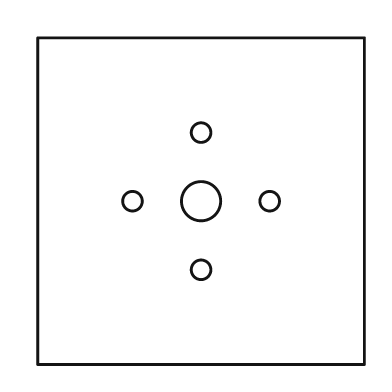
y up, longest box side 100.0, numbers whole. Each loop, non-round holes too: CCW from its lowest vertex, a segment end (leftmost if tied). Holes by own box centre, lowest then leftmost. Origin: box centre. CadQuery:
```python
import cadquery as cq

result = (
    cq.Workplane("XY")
    .moveTo(-50.0, -50.0)
    .lineTo(50.0, -50.0)
    .lineTo(50.0, 50.0)
    .lineTo(-50.0, 50.0)
    .close()
    .moveTo(0.0, -21.0)
    .circle(3.0)
    .moveTo(-21.0, 0.0)
    .circle(3.0)
    .moveTo(0.0, 0.0)
    .circle(6.0)
    .moveTo(21.0, 0.0)
    .circle(3.0)
    .moveTo(0.0, 21.0)
    .circle(3.0)
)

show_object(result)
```